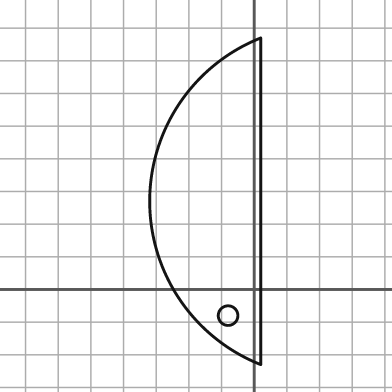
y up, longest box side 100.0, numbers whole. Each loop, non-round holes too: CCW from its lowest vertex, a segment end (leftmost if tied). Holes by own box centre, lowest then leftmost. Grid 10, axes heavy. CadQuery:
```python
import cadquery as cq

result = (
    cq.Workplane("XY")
    .moveTo(2.0, -23.0)
    .lineTo(2.0, 77.0)
    .threePointArc((-32.0, 27.0), (2.0, -23.0))
    .close()
    .moveTo(-8.0, -8.0)
    .circle(3.0)
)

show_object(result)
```